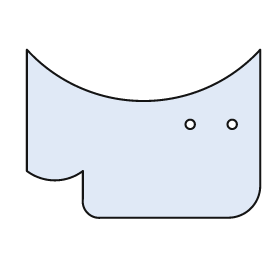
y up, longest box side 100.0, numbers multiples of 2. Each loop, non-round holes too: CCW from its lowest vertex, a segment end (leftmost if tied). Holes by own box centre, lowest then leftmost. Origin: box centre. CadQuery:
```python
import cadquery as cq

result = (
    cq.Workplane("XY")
    .moveTo(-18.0, -36.0)
    .lineTo(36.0, -36.0)
    .threePointArc((46.0, -32.0), (50.0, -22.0))
    .lineTo(50.0, 36.0)
    .threePointArc((0.0, 14.0), (-50.0, 36.0))
    .lineTo(-50.0, -16.0)
    .threePointArc((-38.0, -20.0), (-26.0, -16.0))
    .lineTo(-26.0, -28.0)
    .threePointArc((-24.0, -34.0), (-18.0, -36.0))
    .close()
    .moveTo(20.0, 4.0)
    .circle(2.0)
    .moveTo(38.0, 4.0)
    .circle(2.0)
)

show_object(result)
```